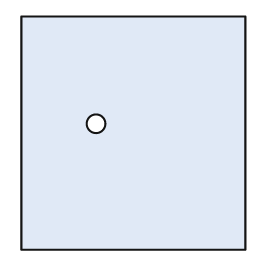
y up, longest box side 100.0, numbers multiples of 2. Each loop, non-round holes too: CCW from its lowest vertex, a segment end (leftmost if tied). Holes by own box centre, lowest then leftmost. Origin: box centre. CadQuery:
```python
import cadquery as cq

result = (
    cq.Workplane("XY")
    .moveTo(-48.0, -50.0)
    .lineTo(48.0, -50.0)
    .lineTo(48.0, 50.0)
    .lineTo(-48.0, 50.0)
    .close()
    .moveTo(-16.0, 4.0)
    .circle(4.0)
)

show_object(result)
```